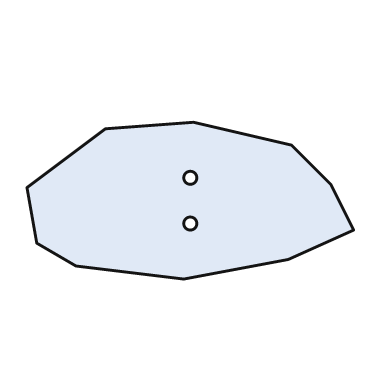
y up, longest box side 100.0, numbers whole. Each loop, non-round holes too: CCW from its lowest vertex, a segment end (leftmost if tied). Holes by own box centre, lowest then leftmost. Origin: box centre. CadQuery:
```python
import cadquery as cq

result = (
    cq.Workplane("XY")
    .moveTo(-2.0, -24.0)
    .lineTo(30.0, -18.0)
    .lineTo(50.0, -9.0)
    .lineTo(43.0, 5.0)
    .lineTo(31.0, 17.0)
    .lineTo(1.0, 24.0)
    .lineTo(-26.0, 22.0)
    .lineTo(-50.0, 4.0)
    .lineTo(-47.0, -13.0)
    .lineTo(-35.0, -20.0)
    .close()
    .moveTo(0.0, -7.0)
    .circle(2.0)
    .moveTo(0.0, 7.0)
    .circle(2.0)
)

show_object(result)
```